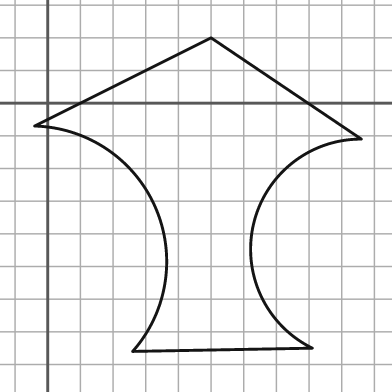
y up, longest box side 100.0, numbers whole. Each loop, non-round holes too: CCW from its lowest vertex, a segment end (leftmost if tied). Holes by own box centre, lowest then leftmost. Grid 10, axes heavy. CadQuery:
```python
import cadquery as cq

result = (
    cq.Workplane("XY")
    .moveTo(26.0, -76.0)
    .lineTo(81.0, -75.0)
    .threePointArc((63.0, -37.0), (96.0, -11.0))
    .lineTo(50.0, 20.0)
    .lineTo(-4.0, -7.0)
    .threePointArc((33.0, -32.0), (26.0, -76.0))
    .close()
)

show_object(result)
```